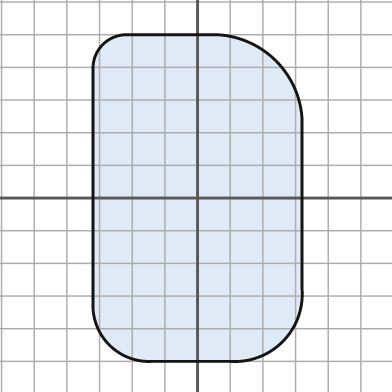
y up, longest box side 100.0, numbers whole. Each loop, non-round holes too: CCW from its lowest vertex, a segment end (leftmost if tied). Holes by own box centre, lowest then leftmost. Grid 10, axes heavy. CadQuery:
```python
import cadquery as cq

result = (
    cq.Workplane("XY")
    .moveTo(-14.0, -50.0)
    .lineTo(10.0, -50.0)
    .threePointArc((26.0, -44.0), (32.0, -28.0))
    .lineTo(32.0, 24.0)
    .threePointArc((24.0, 42.0), (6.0, 50.0))
    .lineTo(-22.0, 50.0)
    .threePointArc((-29.0, 47.0), (-32.0, 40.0))
    .lineTo(-32.0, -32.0)
    .threePointArc((-27.0, -45.0), (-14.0, -50.0))
    .close()
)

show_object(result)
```